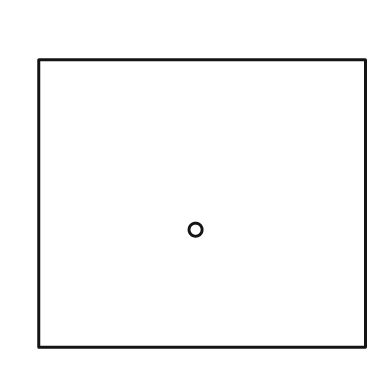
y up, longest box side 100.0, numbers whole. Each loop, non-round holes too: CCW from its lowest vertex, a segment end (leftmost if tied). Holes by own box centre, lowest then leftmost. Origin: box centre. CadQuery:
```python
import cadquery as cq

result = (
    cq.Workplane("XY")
    .moveTo(-50.0, -44.0)
    .lineTo(50.0, -44.0)
    .lineTo(50.0, 44.0)
    .lineTo(-50.0, 44.0)
    .close()
    .moveTo(-2.0, -8.0)
    .circle(2.0)
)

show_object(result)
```